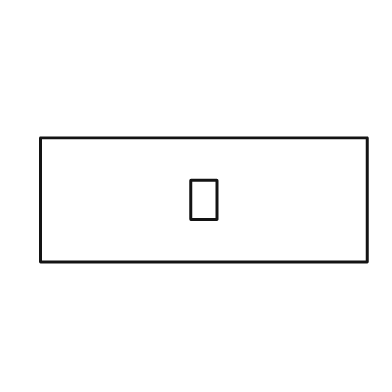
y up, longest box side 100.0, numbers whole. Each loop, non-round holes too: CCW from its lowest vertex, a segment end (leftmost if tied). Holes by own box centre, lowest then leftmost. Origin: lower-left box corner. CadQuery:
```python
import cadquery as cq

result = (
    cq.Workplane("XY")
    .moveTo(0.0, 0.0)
    .lineTo(100.0, 0.0)
    .lineTo(100.0, 38.0)
    .lineTo(0.0, 38.0)
    .close()
    .moveTo(46.0, 13.0)
    .lineTo(54.0, 13.0)
    .lineTo(54.0, 25.0)
    .lineTo(46.0, 25.0)
    .close()
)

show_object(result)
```